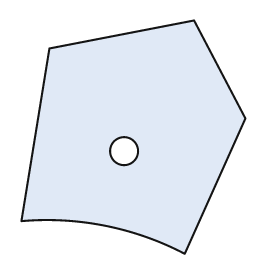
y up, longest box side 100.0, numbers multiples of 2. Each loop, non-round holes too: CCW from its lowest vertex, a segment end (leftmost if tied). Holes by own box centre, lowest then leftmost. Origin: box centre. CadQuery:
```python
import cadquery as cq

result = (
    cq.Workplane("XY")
    .moveTo(22.0, -50.0)
    .lineTo(48.0, 8.0)
    .lineTo(26.0, 50.0)
    .lineTo(-36.0, 38.0)
    .lineTo(-48.0, -36.0)
    .threePointArc((-12.0, -38.0), (22.0, -50.0))
    .close()
    .moveTo(-4.0, -6.0)
    .circle(6.0)
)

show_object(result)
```